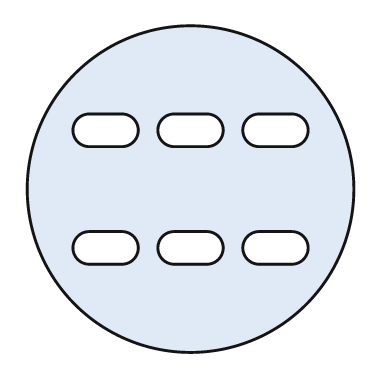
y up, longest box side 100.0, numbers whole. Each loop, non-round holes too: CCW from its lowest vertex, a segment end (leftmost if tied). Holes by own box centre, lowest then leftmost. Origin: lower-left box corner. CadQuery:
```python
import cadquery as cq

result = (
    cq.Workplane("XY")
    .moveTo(50.0, 50.0)
    .circle(50.0)
    .moveTo(19.0, 27.0)
    .lineTo(29.0, 27.0)
    .threePointArc((34.0, 32.0), (29.0, 37.0))
    .lineTo(19.0, 37.0)
    .threePointArc((14.0, 32.0), (19.0, 27.0))
    .close()
    .moveTo(45.0, 27.0)
    .lineTo(55.0, 27.0)
    .threePointArc((60.0, 32.0), (55.0, 37.0))
    .lineTo(45.0, 37.0)
    .threePointArc((40.0, 32.0), (45.0, 27.0))
    .close()
    .moveTo(71.0, 27.0)
    .lineTo(81.0, 27.0)
    .threePointArc((86.0, 32.0), (81.0, 37.0))
    .lineTo(71.0, 37.0)
    .threePointArc((66.0, 32.0), (71.0, 27.0))
    .close()
    .moveTo(19.0, 63.0)
    .lineTo(29.0, 63.0)
    .threePointArc((34.0, 68.0), (29.0, 73.0))
    .lineTo(19.0, 73.0)
    .threePointArc((14.0, 68.0), (19.0, 63.0))
    .close()
    .moveTo(45.0, 63.0)
    .lineTo(55.0, 63.0)
    .threePointArc((60.0, 68.0), (55.0, 73.0))
    .lineTo(45.0, 73.0)
    .threePointArc((40.0, 68.0), (45.0, 63.0))
    .close()
    .moveTo(71.0, 63.0)
    .lineTo(81.0, 63.0)
    .threePointArc((86.0, 68.0), (81.0, 73.0))
    .lineTo(71.0, 73.0)
    .threePointArc((66.0, 68.0), (71.0, 63.0))
    .close()
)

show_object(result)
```